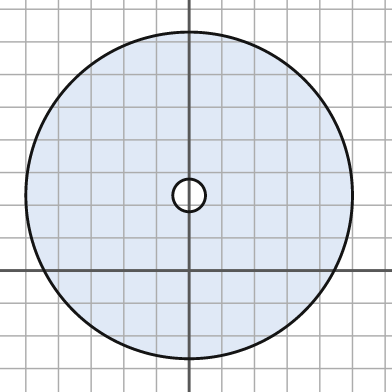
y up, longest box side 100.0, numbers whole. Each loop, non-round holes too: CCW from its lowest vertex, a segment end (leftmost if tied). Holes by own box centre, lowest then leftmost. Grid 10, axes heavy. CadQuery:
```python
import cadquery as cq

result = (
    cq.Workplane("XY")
    .moveTo(0.0, 23.0)
    .circle(50.0)
    .moveTo(0.0, 23.0)
    .circle(5.0)
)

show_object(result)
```